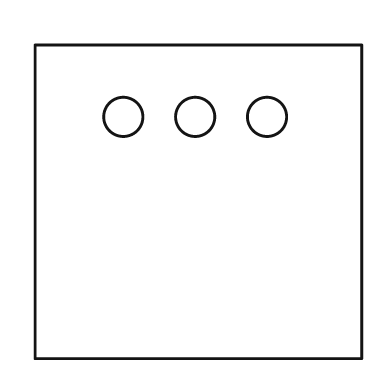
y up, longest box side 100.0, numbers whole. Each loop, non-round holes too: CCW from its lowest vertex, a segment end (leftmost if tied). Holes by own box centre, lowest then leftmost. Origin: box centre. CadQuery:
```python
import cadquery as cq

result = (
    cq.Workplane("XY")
    .moveTo(-50.0, -48.0)
    .lineTo(50.0, -48.0)
    .lineTo(50.0, 48.0)
    .lineTo(-50.0, 48.0)
    .close()
    .moveTo(-23.0, 26.0)
    .circle(6.0)
    .moveTo(-1.0, 26.0)
    .circle(6.0)
    .moveTo(21.0, 26.0)
    .circle(6.0)
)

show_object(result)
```